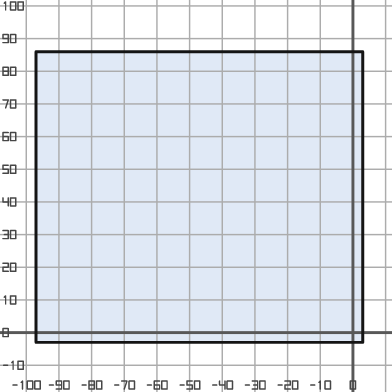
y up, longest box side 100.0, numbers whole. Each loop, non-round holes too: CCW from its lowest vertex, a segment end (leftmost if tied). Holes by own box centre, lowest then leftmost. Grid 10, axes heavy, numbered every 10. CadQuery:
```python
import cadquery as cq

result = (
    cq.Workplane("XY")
    .moveTo(-97.0, -3.0)
    .lineTo(3.0, -3.0)
    .lineTo(3.0, 86.0)
    .lineTo(-97.0, 86.0)
    .close()
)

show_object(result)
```